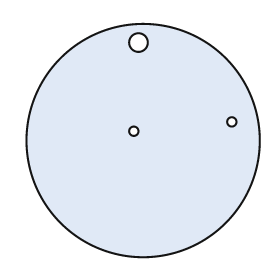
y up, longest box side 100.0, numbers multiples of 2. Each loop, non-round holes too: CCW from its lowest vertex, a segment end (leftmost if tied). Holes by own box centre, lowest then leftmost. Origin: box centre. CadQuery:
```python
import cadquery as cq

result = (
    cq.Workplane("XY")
    .moveTo(0.0, 0.0)
    .circle(50.0)
    .moveTo(-4.0, 4.0)
    .circle(2.0)
    .moveTo(38.0, 8.0)
    .circle(2.0)
    .moveTo(-2.0, 42.0)
    .circle(4.0)
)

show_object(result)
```